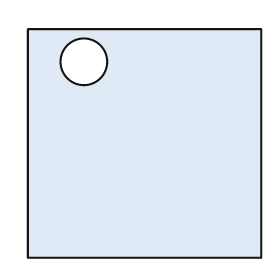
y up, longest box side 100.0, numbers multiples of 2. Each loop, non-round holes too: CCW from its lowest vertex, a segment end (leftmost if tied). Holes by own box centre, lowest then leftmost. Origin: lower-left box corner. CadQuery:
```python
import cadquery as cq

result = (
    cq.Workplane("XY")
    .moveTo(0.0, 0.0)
    .lineTo(100.0, 0.0)
    .lineTo(100.0, 98.0)
    .lineTo(0.0, 98.0)
    .close()
    .moveTo(24.0, 84.0)
    .circle(10.0)
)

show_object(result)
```